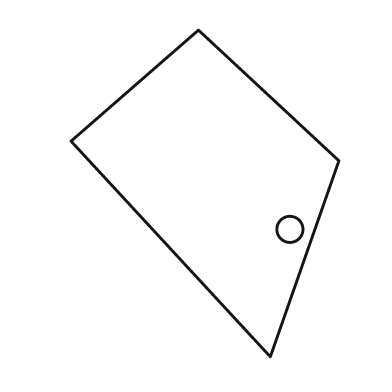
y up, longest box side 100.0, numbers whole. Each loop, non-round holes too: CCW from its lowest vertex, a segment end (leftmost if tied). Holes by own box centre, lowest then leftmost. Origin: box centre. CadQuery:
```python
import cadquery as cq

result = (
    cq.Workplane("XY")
    .moveTo(20.0, -50.0)
    .lineTo(41.0, 10.0)
    .lineTo(-2.0, 50.0)
    .lineTo(-41.0, 16.0)
    .close()
    .moveTo(26.0, -11.0)
    .circle(4.0)
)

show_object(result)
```